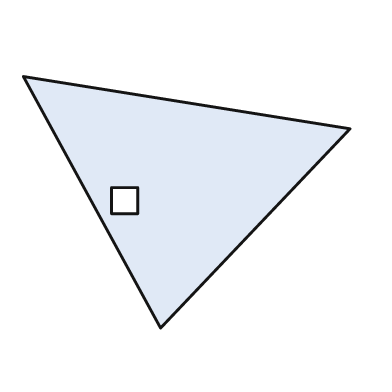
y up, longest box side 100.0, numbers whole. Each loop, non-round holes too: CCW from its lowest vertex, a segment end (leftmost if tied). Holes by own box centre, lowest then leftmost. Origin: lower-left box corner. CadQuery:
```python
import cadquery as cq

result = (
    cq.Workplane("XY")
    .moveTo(42.0, 0.0)
    .lineTo(100.0, 61.0)
    .lineTo(0.0, 77.0)
    .close()
    .moveTo(27.0, 35.0)
    .lineTo(35.0, 35.0)
    .lineTo(35.0, 43.0)
    .lineTo(27.0, 43.0)
    .close()
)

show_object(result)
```